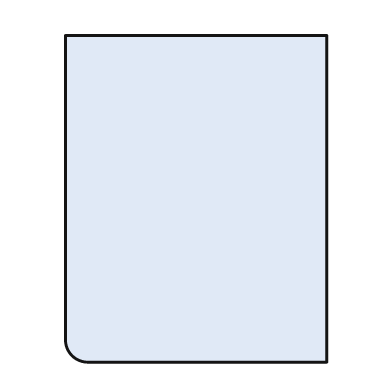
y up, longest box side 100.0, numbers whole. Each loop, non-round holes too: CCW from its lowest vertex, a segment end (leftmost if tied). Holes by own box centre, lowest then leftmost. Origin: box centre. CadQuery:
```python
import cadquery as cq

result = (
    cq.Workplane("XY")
    .moveTo(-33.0, -50.0)
    .lineTo(40.0, -50.0)
    .lineTo(40.0, 50.0)
    .lineTo(-40.0, 50.0)
    .lineTo(-40.0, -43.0)
    .threePointArc((-38.0, -48.0), (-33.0, -50.0))
    .close()
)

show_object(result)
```